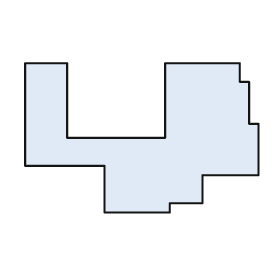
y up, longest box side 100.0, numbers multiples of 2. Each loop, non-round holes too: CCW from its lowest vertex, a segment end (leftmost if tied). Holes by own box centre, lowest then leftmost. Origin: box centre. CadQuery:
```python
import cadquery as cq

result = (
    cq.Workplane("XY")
    .moveTo(-16.0, -32.0)
    .lineTo(12.0, -32.0)
    .lineTo(12.0, -28.0)
    .lineTo(26.0, -28.0)
    .lineTo(26.0, -16.0)
    .lineTo(50.0, -16.0)
    .lineTo(50.0, 6.0)
    .lineTo(46.0, 6.0)
    .lineTo(46.0, 24.0)
    .lineTo(42.0, 24.0)
    .lineTo(42.0, 32.0)
    .lineTo(10.0, 32.0)
    .lineTo(10.0, 0.0)
    .lineTo(-32.0, 0.0)
    .lineTo(-32.0, 32.0)
    .lineTo(-50.0, 32.0)
    .lineTo(-50.0, -12.0)
    .lineTo(-16.0, -12.0)
    .close()
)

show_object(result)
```